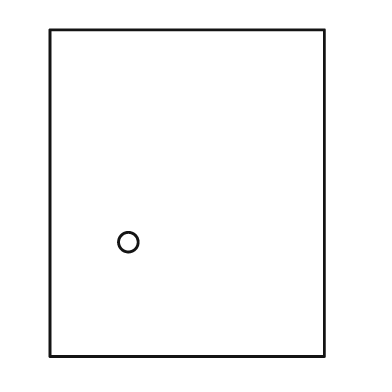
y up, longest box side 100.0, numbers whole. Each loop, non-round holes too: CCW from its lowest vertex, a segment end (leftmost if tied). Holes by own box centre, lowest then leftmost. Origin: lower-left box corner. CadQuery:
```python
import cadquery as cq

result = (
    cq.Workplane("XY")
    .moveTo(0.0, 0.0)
    .lineTo(84.0, 0.0)
    .lineTo(84.0, 100.0)
    .lineTo(0.0, 100.0)
    .close()
    .moveTo(24.0, 35.0)
    .circle(3.0)
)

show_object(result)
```